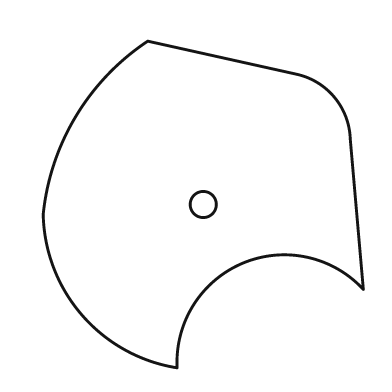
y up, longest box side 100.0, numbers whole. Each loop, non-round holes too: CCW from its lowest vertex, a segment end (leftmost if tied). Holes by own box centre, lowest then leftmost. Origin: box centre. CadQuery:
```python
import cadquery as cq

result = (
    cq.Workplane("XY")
    .moveTo(-8.0, -50.0)
    .threePointArc((12.0, -18.0), (49.0, -26.0))
    .lineTo(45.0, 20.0)
    .threePointArc((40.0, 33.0), (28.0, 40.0))
    .lineTo(-17.0, 50.0)
    .threePointArc((-39.0, 27.0), (-49.0, -3.0))
    .threePointArc((-37.0, -34.0), (-8.0, -50.0))
    .close()
    .moveTo(0.0, 0.0)
    .circle(4.0)
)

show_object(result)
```